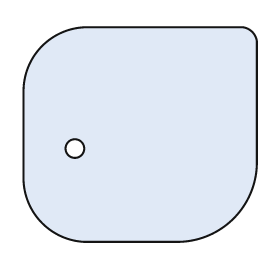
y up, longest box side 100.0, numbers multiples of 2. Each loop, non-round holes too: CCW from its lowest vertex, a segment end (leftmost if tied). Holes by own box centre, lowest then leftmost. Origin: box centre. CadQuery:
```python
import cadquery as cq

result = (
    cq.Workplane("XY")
    .moveTo(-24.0, -46.0)
    .lineTo(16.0, -46.0)
    .threePointArc((40.0, -36.0), (50.0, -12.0))
    .lineTo(50.0, 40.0)
    .threePointArc((48.0, 44.0), (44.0, 46.0))
    .lineTo(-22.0, 46.0)
    .threePointArc((-42.0, 38.0), (-50.0, 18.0))
    .lineTo(-50.0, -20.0)
    .threePointArc((-42.0, -38.0), (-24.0, -46.0))
    .close()
    .moveTo(-28.0, -6.0)
    .circle(4.0)
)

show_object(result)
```